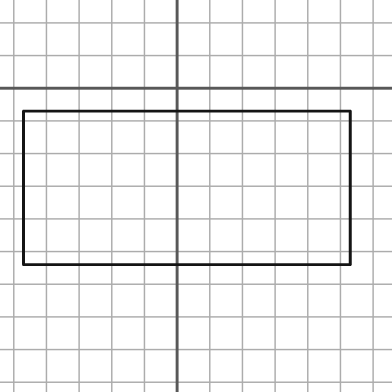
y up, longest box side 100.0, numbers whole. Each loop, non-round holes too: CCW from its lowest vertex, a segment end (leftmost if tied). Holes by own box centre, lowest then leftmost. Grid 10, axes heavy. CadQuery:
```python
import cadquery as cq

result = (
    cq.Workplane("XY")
    .moveTo(-47.0, -54.0)
    .lineTo(53.0, -54.0)
    .lineTo(53.0, -7.0)
    .lineTo(-47.0, -7.0)
    .close()
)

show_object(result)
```